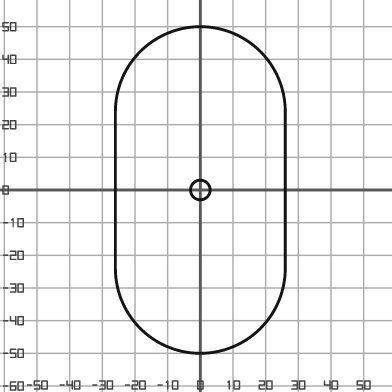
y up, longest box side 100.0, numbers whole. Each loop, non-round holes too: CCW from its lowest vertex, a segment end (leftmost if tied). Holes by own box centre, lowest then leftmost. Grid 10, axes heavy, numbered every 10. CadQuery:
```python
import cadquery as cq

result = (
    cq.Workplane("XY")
    .moveTo(-26.0, -24.0)
    .threePointArc((0.0, -50.0), (26.0, -24.0))
    .lineTo(26.0, 24.0)
    .threePointArc((0.0, 50.0), (-26.0, 24.0))
    .close()
    .moveTo(0.0, 0.0)
    .circle(3.0)
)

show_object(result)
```